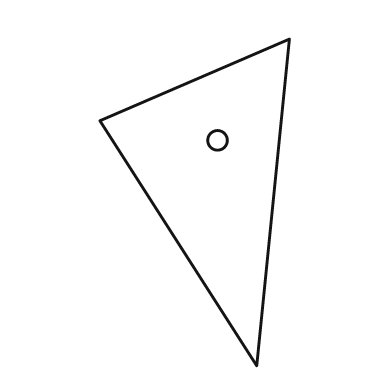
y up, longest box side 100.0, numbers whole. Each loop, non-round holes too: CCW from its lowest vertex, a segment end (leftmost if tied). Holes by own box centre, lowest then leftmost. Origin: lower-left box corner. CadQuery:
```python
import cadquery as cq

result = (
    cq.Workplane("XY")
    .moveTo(48.0, 0.0)
    .lineTo(58.0, 100.0)
    .lineTo(0.0, 75.0)
    .close()
    .moveTo(36.0, 69.0)
    .circle(3.0)
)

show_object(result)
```